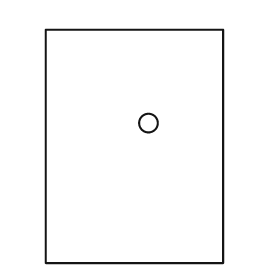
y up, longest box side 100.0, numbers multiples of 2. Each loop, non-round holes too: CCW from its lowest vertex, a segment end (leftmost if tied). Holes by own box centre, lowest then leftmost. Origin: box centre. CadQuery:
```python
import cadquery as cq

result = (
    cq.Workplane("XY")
    .moveTo(-38.0, -50.0)
    .lineTo(38.0, -50.0)
    .lineTo(38.0, 50.0)
    .lineTo(-38.0, 50.0)
    .close()
    .moveTo(6.0, 10.0)
    .circle(4.0)
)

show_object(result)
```